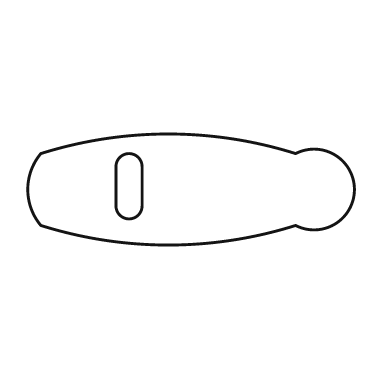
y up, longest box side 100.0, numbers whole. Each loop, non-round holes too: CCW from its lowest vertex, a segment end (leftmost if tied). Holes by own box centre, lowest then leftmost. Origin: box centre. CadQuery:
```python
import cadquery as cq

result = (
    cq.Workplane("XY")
    .moveTo(-46.0, -11.0)
    .threePointArc((-7.0, -17.0), (32.0, -11.0))
    .threePointArc((50.0, 0.0), (32.0, 11.0))
    .threePointArc((-7.0, 17.0), (-46.0, 11.0))
    .threePointArc((-50.0, 0.0), (-46.0, -11.0))
    .close()
    .moveTo(-23.0, -5.0)
    .threePointArc((-19.0, -9.0), (-15.0, -5.0))
    .lineTo(-15.0, 7.0)
    .threePointArc((-19.0, 11.0), (-23.0, 7.0))
    .close()
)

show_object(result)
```